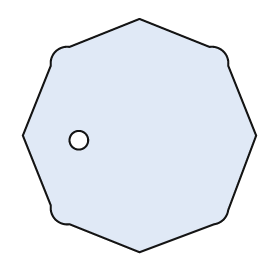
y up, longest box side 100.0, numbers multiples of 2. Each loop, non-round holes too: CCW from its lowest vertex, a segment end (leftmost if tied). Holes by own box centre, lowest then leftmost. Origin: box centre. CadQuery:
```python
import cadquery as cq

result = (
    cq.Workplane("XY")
    .moveTo(0.0, -50.0)
    .lineTo(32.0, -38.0)
    .threePointArc((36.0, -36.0), (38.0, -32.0))
    .lineTo(50.0, 0.0)
    .lineTo(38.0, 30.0)
    .threePointArc((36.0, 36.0), (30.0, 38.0))
    .lineTo(0.0, 50.0)
    .lineTo(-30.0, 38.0)
    .threePointArc((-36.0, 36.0), (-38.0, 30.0))
    .lineTo(-50.0, 0.0)
    .lineTo(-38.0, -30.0)
    .threePointArc((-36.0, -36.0), (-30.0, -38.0))
    .close()
    .moveTo(-26.0, -2.0)
    .circle(4.0)
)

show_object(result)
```